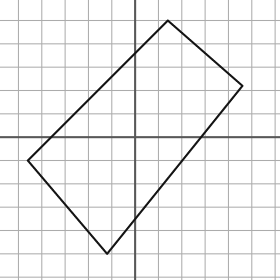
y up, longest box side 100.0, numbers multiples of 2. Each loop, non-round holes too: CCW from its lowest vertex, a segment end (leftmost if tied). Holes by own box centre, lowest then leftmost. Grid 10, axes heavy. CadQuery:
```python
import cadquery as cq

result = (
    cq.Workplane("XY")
    .moveTo(-12.0, -50.0)
    .lineTo(46.0, 22.0)
    .lineTo(14.0, 50.0)
    .lineTo(-46.0, -10.0)
    .close()
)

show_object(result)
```